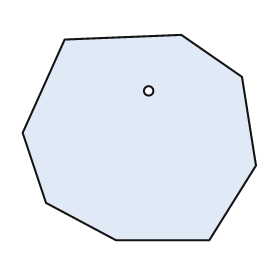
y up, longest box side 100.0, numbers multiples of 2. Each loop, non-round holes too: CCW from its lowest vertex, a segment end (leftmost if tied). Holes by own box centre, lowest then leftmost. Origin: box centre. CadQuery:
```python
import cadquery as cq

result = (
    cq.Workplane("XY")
    .moveTo(-10.0, -44.0)
    .lineTo(30.0, -44.0)
    .lineTo(50.0, -12.0)
    .lineTo(44.0, 26.0)
    .lineTo(18.0, 44.0)
    .lineTo(-32.0, 42.0)
    .lineTo(-50.0, 2.0)
    .lineTo(-40.0, -28.0)
    .close()
    .moveTo(4.0, 20.0)
    .circle(2.0)
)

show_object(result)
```